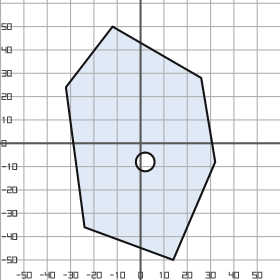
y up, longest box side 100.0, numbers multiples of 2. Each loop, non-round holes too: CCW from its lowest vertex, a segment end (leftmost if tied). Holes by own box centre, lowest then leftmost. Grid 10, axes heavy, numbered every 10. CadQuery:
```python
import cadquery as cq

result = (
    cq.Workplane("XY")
    .moveTo(14.0, -50.0)
    .lineTo(32.0, -8.0)
    .lineTo(26.0, 28.0)
    .lineTo(-12.0, 50.0)
    .lineTo(-32.0, 24.0)
    .lineTo(-24.0, -36.0)
    .close()
    .moveTo(2.0, -8.0)
    .circle(4.0)
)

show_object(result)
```